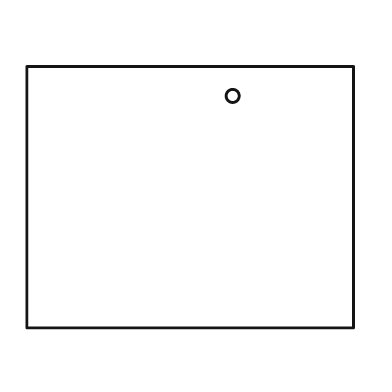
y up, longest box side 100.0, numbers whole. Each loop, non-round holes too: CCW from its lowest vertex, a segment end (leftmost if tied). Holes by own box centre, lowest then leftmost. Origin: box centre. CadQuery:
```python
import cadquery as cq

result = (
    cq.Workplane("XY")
    .moveTo(-50.0, -40.0)
    .lineTo(50.0, -40.0)
    .lineTo(50.0, 40.0)
    .lineTo(-50.0, 40.0)
    .close()
    .moveTo(13.0, 31.0)
    .circle(2.0)
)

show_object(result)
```